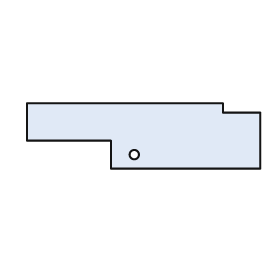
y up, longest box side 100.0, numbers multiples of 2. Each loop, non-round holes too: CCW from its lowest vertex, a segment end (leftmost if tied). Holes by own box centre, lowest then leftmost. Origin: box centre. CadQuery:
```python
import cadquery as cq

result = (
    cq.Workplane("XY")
    .moveTo(-14.0, -14.0)
    .lineTo(50.0, -14.0)
    .lineTo(50.0, 10.0)
    .lineTo(34.0, 10.0)
    .lineTo(34.0, 14.0)
    .lineTo(-50.0, 14.0)
    .lineTo(-50.0, -2.0)
    .lineTo(-14.0, -2.0)
    .close()
    .moveTo(-4.0, -8.0)
    .circle(2.0)
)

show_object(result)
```